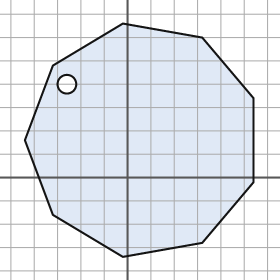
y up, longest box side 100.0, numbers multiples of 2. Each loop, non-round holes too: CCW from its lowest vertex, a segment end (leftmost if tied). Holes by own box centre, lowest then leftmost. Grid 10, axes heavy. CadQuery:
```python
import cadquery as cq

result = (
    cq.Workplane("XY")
    .moveTo(-2.0, -34.0)
    .lineTo(32.0, -28.0)
    .lineTo(54.0, -2.0)
    .lineTo(54.0, 34.0)
    .lineTo(32.0, 60.0)
    .lineTo(-2.0, 66.0)
    .lineTo(-32.0, 48.0)
    .lineTo(-44.0, 16.0)
    .lineTo(-32.0, -16.0)
    .close()
    .moveTo(-26.0, 40.0)
    .circle(4.0)
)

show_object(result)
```